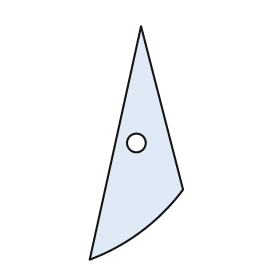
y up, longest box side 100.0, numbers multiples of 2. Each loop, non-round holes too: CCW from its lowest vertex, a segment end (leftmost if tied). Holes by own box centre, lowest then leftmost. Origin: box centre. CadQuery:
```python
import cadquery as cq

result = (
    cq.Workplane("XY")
    .moveTo(-20.0, -50.0)
    .threePointArc((2.0, -38.0), (20.0, -20.0))
    .lineTo(2.0, 50.0)
    .close()
    .moveTo(0.0, 0.0)
    .circle(4.0)
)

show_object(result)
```